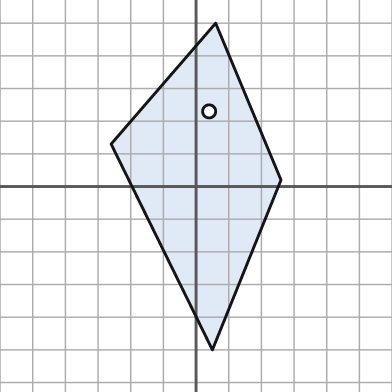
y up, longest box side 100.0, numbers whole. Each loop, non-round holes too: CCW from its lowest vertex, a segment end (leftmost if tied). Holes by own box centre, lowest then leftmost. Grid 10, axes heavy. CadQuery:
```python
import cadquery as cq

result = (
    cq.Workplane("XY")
    .moveTo(5.0, -50.0)
    .lineTo(26.0, 2.0)
    .lineTo(6.0, 50.0)
    .lineTo(-26.0, 13.0)
    .close()
    .moveTo(4.0, 23.0)
    .circle(2.0)
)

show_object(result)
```